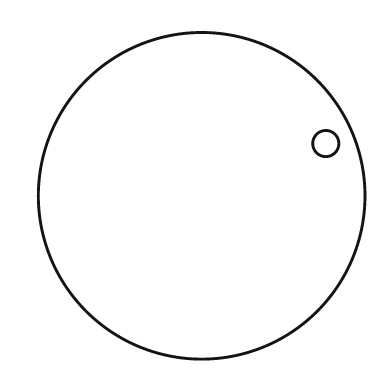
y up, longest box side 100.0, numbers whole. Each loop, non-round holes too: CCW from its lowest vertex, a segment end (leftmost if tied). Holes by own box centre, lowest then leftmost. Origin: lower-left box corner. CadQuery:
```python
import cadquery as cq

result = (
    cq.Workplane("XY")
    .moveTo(50.0, 50.0)
    .circle(50.0)
    .moveTo(88.0, 66.0)
    .circle(4.0)
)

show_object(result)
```